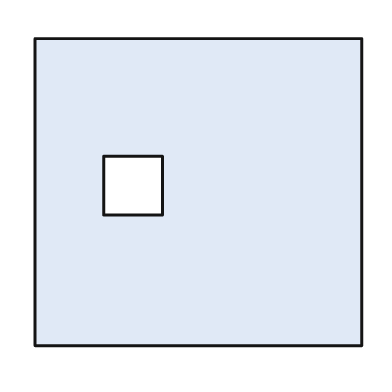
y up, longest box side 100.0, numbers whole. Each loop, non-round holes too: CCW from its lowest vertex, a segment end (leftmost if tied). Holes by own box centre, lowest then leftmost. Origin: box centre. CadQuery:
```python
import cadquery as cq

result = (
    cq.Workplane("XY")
    .moveTo(-50.0, -47.0)
    .lineTo(50.0, -47.0)
    .lineTo(50.0, 47.0)
    .lineTo(-50.0, 47.0)
    .close()
    .moveTo(-29.0, -7.0)
    .lineTo(-11.0, -7.0)
    .lineTo(-11.0, 11.0)
    .lineTo(-29.0, 11.0)
    .close()
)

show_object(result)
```